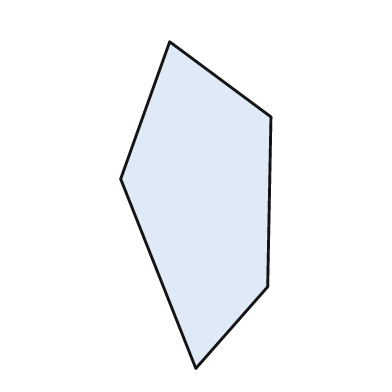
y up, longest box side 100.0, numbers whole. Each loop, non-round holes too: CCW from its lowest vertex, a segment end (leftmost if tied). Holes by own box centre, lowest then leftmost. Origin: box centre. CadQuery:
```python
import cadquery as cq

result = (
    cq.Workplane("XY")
    .moveTo(0.0, -50.0)
    .lineTo(22.0, -25.0)
    .lineTo(23.0, 27.0)
    .lineTo(-8.0, 50.0)
    .lineTo(-23.0, 8.0)
    .close()
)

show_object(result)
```